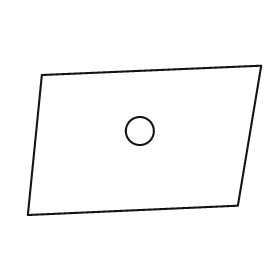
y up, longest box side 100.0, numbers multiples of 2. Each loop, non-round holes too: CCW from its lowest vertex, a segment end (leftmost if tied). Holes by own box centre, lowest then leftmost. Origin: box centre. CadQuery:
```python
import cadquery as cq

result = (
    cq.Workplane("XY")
    .moveTo(-50.0, -32.0)
    .lineTo(40.0, -28.0)
    .lineTo(50.0, 32.0)
    .lineTo(-44.0, 28.0)
    .close()
    .moveTo(-2.0, 4.0)
    .circle(6.0)
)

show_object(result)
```